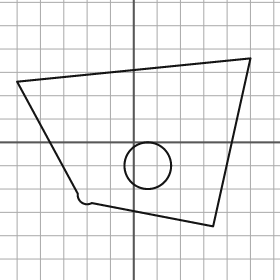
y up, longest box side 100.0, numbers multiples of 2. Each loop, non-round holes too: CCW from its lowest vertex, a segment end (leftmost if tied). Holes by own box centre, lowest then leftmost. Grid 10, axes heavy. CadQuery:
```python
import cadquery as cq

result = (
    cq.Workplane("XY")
    .moveTo(34.0, -36.0)
    .lineTo(50.0, 36.0)
    .lineTo(-50.0, 26.0)
    .lineTo(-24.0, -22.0)
    .threePointArc((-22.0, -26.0), (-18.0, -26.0))
    .close()
    .moveTo(6.0, -10.0)
    .circle(10.0)
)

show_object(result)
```